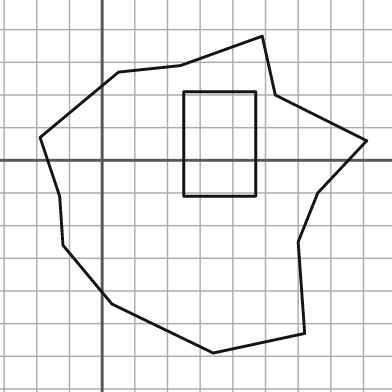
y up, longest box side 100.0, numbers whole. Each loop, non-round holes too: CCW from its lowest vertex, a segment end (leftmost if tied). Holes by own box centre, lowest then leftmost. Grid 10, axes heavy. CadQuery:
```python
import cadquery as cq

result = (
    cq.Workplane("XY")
    .moveTo(34.0, -59.0)
    .lineTo(62.0, -53.0)
    .lineTo(60.0, -25.0)
    .lineTo(66.0, -10.0)
    .lineTo(81.0, 6.0)
    .lineTo(53.0, 20.0)
    .lineTo(49.0, 38.0)
    .lineTo(24.0, 29.0)
    .lineTo(5.0, 27.0)
    .lineTo(-19.0, 7.0)
    .lineTo(-13.0, -11.0)
    .lineTo(-12.0, -26.0)
    .lineTo(3.0, -44.0)
    .close()
    .moveTo(25.0, -11.0)
    .lineTo(47.0, -11.0)
    .lineTo(47.0, 21.0)
    .lineTo(25.0, 21.0)
    .close()
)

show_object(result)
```